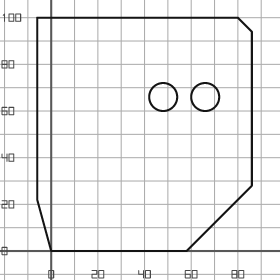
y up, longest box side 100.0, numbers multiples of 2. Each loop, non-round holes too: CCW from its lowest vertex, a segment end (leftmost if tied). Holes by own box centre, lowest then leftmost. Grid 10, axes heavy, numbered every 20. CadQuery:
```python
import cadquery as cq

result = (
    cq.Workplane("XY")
    .moveTo(0.0, 0.0)
    .lineTo(58.0, 0.0)
    .lineTo(86.0, 28.0)
    .lineTo(86.0, 94.0)
    .lineTo(80.0, 100.0)
    .lineTo(-6.0, 100.0)
    .lineTo(-6.0, 22.0)
    .close()
    .moveTo(48.0, 66.0)
    .circle(6.0)
    .moveTo(66.0, 66.0)
    .circle(6.0)
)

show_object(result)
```